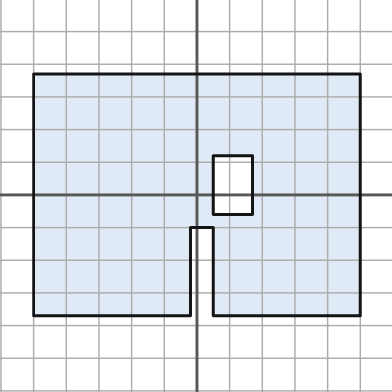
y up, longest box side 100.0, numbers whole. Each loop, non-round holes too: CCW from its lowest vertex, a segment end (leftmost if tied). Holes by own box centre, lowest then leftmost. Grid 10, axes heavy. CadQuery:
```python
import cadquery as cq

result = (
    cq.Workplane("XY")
    .moveTo(-50.0, -37.0)
    .lineTo(-2.0, -37.0)
    .lineTo(-2.0, -10.0)
    .lineTo(5.0, -10.0)
    .lineTo(5.0, -37.0)
    .lineTo(50.0, -37.0)
    .lineTo(50.0, 37.0)
    .lineTo(-50.0, 37.0)
    .close()
    .moveTo(5.0, -6.0)
    .lineTo(17.0, -6.0)
    .lineTo(17.0, 12.0)
    .lineTo(5.0, 12.0)
    .close()
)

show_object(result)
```